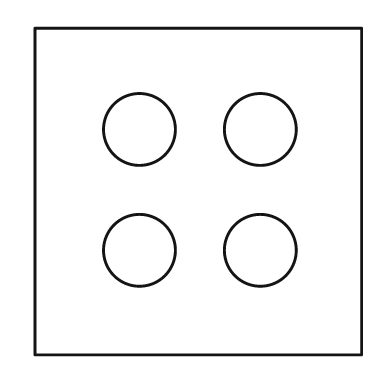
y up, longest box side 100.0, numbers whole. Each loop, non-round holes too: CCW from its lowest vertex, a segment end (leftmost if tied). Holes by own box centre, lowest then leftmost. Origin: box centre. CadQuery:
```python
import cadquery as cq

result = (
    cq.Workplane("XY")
    .moveTo(-50.0, -50.0)
    .lineTo(50.0, -50.0)
    .lineTo(50.0, 50.0)
    .lineTo(-50.0, 50.0)
    .close()
    .moveTo(-18.0, -18.0)
    .circle(11.0)
    .moveTo(19.0, -18.0)
    .circle(11.0)
    .moveTo(-18.0, 19.0)
    .circle(11.0)
    .moveTo(19.0, 19.0)
    .circle(11.0)
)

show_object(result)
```